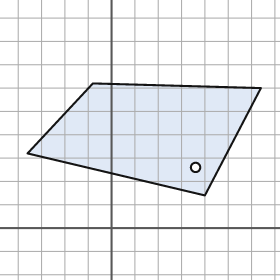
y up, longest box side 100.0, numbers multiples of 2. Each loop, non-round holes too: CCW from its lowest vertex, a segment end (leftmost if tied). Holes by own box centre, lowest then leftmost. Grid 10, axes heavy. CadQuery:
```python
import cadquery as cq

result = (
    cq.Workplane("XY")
    .moveTo(40.0, 14.0)
    .lineTo(64.0, 60.0)
    .lineTo(-8.0, 62.0)
    .lineTo(-36.0, 32.0)
    .close()
    .moveTo(36.0, 26.0)
    .circle(2.0)
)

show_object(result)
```